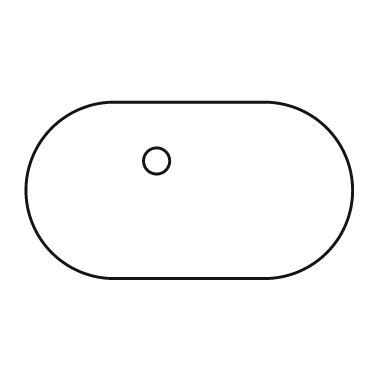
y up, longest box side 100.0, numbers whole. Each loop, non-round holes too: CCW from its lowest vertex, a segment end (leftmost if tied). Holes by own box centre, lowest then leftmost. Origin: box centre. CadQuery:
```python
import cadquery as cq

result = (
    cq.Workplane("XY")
    .moveTo(-23.0, -27.0)
    .lineTo(23.0, -27.0)
    .threePointArc((50.0, 0.0), (23.0, 27.0))
    .lineTo(-23.0, 27.0)
    .threePointArc((-50.0, 0.0), (-23.0, -27.0))
    .close()
    .moveTo(-10.0, 9.0)
    .circle(4.0)
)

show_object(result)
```